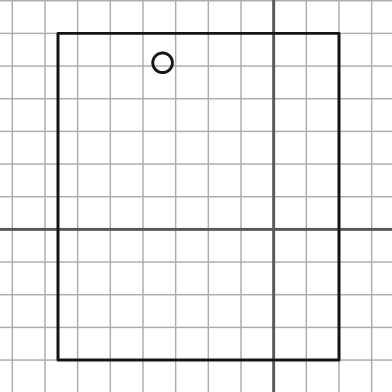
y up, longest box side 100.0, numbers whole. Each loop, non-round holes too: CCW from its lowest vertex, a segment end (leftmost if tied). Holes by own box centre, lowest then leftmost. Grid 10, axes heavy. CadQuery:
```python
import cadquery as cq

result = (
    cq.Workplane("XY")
    .moveTo(-66.0, -40.0)
    .lineTo(20.0, -40.0)
    .lineTo(20.0, 60.0)
    .lineTo(-66.0, 60.0)
    .close()
    .moveTo(-34.0, 51.0)
    .circle(3.0)
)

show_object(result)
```